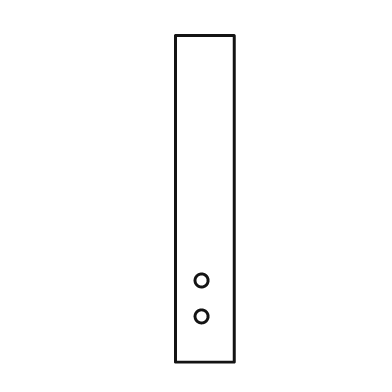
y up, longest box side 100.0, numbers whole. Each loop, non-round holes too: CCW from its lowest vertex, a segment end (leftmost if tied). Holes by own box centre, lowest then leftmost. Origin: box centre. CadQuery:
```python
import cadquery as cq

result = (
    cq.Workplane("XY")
    .moveTo(-9.0, -50.0)
    .lineTo(9.0, -50.0)
    .lineTo(9.0, 50.0)
    .lineTo(-9.0, 50.0)
    .close()
    .moveTo(-1.0, -36.0)
    .circle(2.0)
    .moveTo(-1.0, -25.0)
    .circle(2.0)
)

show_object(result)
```